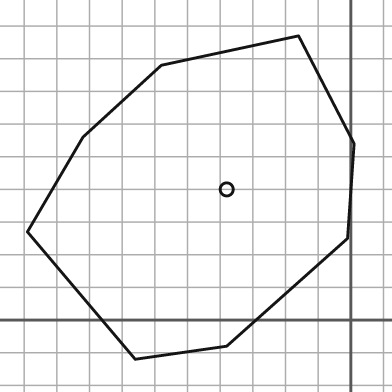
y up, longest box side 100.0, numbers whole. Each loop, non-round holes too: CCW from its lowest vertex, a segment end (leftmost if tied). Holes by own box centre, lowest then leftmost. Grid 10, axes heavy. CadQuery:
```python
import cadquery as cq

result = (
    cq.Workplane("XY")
    .moveTo(-66.0, -12.0)
    .lineTo(-38.0, -8.0)
    .lineTo(-1.0, 25.0)
    .lineTo(1.0, 54.0)
    .lineTo(-16.0, 87.0)
    .lineTo(-58.0, 78.0)
    .lineTo(-82.0, 56.0)
    .lineTo(-99.0, 27.0)
    .close()
    .moveTo(-38.0, 40.0)
    .circle(2.0)
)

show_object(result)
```